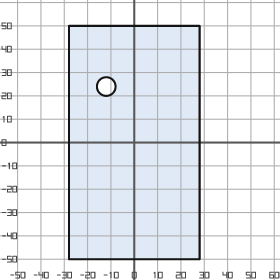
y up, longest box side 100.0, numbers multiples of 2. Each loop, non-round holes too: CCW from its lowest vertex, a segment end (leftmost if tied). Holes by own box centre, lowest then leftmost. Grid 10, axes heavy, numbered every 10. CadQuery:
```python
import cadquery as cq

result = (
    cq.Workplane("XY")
    .moveTo(-28.0, -50.0)
    .lineTo(28.0, -50.0)
    .lineTo(28.0, 50.0)
    .lineTo(-28.0, 50.0)
    .close()
    .moveTo(-12.0, 24.0)
    .circle(4.0)
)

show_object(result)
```